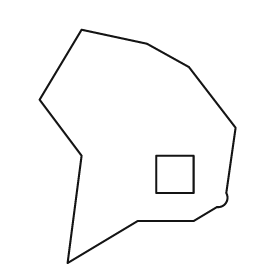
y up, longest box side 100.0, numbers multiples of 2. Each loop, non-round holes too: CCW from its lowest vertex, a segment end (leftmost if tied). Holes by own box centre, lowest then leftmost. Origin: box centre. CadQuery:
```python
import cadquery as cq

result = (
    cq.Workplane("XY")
    .moveTo(-30.0, -50.0)
    .lineTo(0.0, -32.0)
    .lineTo(24.0, -32.0)
    .lineTo(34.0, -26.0)
    .threePointArc((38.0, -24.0), (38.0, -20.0))
    .lineTo(42.0, 8.0)
    .lineTo(22.0, 34.0)
    .lineTo(4.0, 44.0)
    .lineTo(-24.0, 50.0)
    .lineTo(-42.0, 20.0)
    .lineTo(-24.0, -4.0)
    .close()
    .moveTo(8.0, -20.0)
    .lineTo(24.0, -20.0)
    .lineTo(24.0, -4.0)
    .lineTo(8.0, -4.0)
    .close()
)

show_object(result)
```